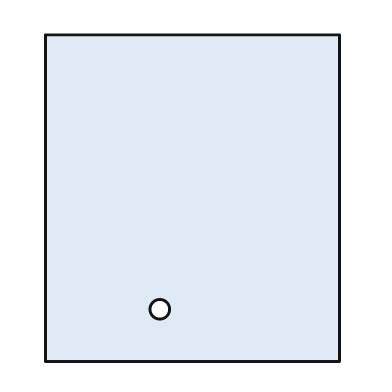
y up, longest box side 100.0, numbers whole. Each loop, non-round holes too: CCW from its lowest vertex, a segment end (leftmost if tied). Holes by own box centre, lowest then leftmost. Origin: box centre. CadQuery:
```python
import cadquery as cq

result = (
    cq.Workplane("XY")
    .moveTo(-45.0, -50.0)
    .lineTo(45.0, -50.0)
    .lineTo(45.0, 50.0)
    .lineTo(-45.0, 50.0)
    .close()
    .moveTo(-10.0, -34.0)
    .circle(3.0)
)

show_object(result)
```